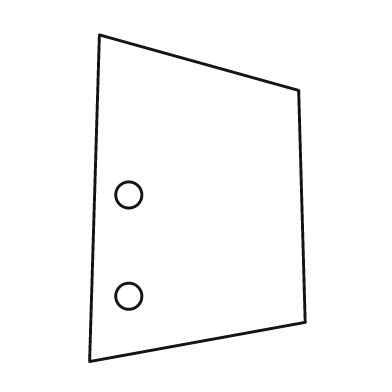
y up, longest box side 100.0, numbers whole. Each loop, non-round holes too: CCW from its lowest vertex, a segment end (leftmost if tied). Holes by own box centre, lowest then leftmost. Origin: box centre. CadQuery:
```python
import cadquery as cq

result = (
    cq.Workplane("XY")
    .moveTo(-33.0, -50.0)
    .lineTo(33.0, -38.0)
    .lineTo(31.0, 33.0)
    .lineTo(-30.0, 50.0)
    .close()
    .moveTo(-21.0, -30.0)
    .circle(4.0)
    .moveTo(-21.0, 1.0)
    .circle(4.0)
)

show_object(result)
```